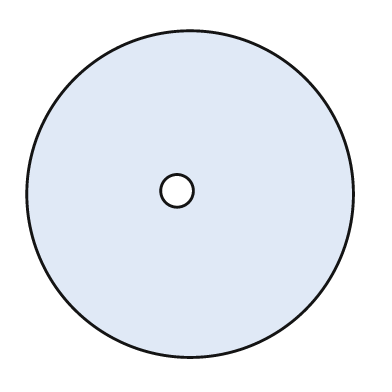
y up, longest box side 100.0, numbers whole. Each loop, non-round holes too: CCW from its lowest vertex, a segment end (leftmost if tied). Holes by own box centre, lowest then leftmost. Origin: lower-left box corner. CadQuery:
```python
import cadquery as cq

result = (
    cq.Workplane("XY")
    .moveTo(50.0, 50.0)
    .circle(50.0)
    .moveTo(46.0, 51.0)
    .circle(5.0)
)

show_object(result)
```